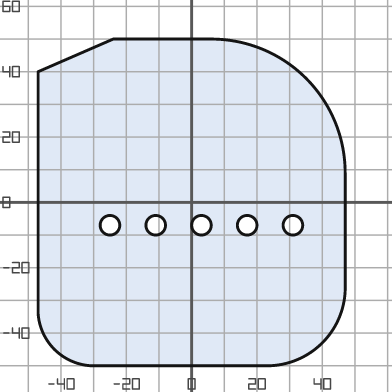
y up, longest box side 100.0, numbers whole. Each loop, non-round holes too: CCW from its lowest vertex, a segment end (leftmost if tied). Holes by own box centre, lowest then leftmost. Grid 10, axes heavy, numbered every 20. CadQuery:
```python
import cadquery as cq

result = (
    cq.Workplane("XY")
    .moveTo(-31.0, -50.0)
    .lineTo(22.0, -50.0)
    .threePointArc((40.0, -43.0), (47.0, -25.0))
    .lineTo(47.0, 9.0)
    .threePointArc((35.0, 38.0), (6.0, 50.0))
    .lineTo(-24.0, 50.0)
    .lineTo(-47.0, 40.0)
    .lineTo(-47.0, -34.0)
    .threePointArc((-42.0, -45.0), (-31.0, -50.0))
    .close()
    .moveTo(-25.0, -7.0)
    .circle(3.0)
    .moveTo(-11.0, -7.0)
    .circle(3.0)
    .moveTo(3.0, -7.0)
    .circle(3.0)
    .moveTo(17.0, -7.0)
    .circle(3.0)
    .moveTo(31.0, -7.0)
    .circle(3.0)
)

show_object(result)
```